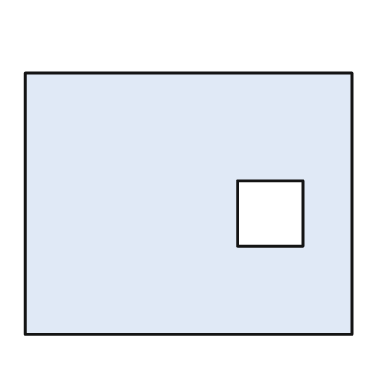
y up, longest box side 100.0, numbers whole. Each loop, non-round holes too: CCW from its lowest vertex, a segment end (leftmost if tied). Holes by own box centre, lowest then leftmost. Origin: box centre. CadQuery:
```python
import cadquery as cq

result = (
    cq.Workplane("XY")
    .moveTo(-50.0, -40.0)
    .lineTo(50.0, -40.0)
    .lineTo(50.0, 40.0)
    .lineTo(-50.0, 40.0)
    .close()
    .moveTo(15.0, -13.0)
    .lineTo(35.0, -13.0)
    .lineTo(35.0, 7.0)
    .lineTo(15.0, 7.0)
    .close()
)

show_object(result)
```